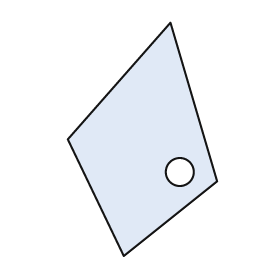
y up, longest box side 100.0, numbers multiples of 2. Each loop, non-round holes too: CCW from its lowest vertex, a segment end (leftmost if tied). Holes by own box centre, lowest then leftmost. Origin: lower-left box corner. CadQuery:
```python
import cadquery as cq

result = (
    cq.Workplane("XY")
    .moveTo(24.0, 0.0)
    .lineTo(64.0, 32.0)
    .lineTo(44.0, 100.0)
    .lineTo(0.0, 50.0)
    .close()
    .moveTo(48.0, 36.0)
    .circle(6.0)
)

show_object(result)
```